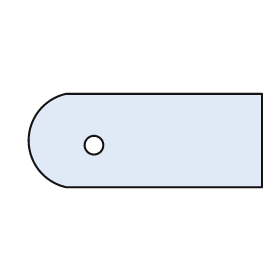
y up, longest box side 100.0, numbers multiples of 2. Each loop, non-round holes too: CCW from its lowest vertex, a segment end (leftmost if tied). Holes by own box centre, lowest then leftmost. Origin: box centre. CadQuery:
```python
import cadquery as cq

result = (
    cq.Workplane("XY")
    .moveTo(-34.0, -20.0)
    .lineTo(50.0, -20.0)
    .lineTo(50.0, 20.0)
    .lineTo(-34.0, 20.0)
    .threePointArc((-50.0, 0.0), (-34.0, -20.0))
    .close()
    .moveTo(-22.0, -2.0)
    .circle(4.0)
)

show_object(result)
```